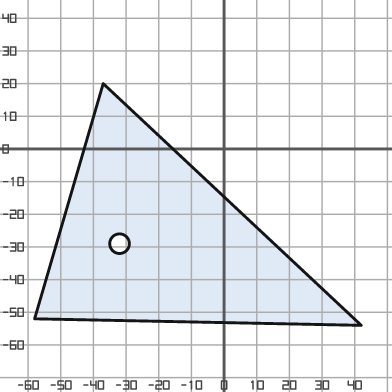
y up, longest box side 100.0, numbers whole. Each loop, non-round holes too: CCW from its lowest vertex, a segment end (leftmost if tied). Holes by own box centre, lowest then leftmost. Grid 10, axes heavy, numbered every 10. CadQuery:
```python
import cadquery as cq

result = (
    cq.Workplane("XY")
    .moveTo(42.0, -54.0)
    .lineTo(-37.0, 20.0)
    .lineTo(-58.0, -52.0)
    .close()
    .moveTo(-32.0, -29.0)
    .circle(3.0)
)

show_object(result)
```